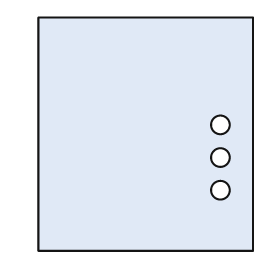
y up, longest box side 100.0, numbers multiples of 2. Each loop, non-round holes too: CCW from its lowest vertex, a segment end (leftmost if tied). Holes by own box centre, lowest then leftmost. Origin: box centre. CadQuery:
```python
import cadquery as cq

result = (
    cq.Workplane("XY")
    .moveTo(-46.0, -50.0)
    .lineTo(46.0, -50.0)
    .lineTo(46.0, 50.0)
    .lineTo(-46.0, 50.0)
    .close()
    .moveTo(32.0, -24.0)
    .circle(4.0)
    .moveTo(32.0, -10.0)
    .circle(4.0)
    .moveTo(32.0, 4.0)
    .circle(4.0)
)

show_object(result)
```